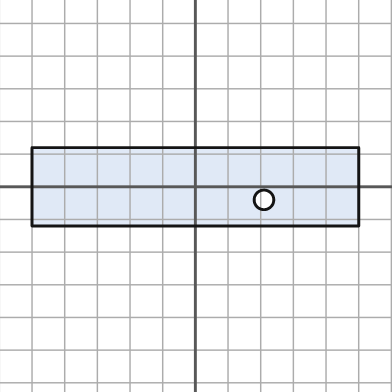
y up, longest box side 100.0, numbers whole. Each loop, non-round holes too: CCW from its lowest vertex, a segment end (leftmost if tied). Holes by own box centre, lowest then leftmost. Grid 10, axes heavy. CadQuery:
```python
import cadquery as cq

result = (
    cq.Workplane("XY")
    .moveTo(-50.0, -12.0)
    .lineTo(50.0, -12.0)
    .lineTo(50.0, 12.0)
    .lineTo(-50.0, 12.0)
    .close()
    .moveTo(21.0, -4.0)
    .circle(3.0)
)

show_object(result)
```